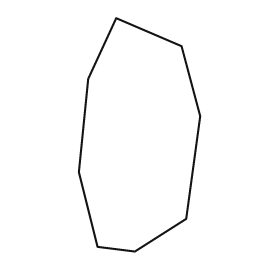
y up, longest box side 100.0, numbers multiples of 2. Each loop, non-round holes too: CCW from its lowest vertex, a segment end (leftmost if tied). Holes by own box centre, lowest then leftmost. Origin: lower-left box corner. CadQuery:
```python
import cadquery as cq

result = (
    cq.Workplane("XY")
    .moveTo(24.0, 0.0)
    .lineTo(46.0, 14.0)
    .lineTo(52.0, 58.0)
    .lineTo(44.0, 88.0)
    .lineTo(16.0, 100.0)
    .lineTo(4.0, 74.0)
    .lineTo(0.0, 34.0)
    .lineTo(8.0, 2.0)
    .close()
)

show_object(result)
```